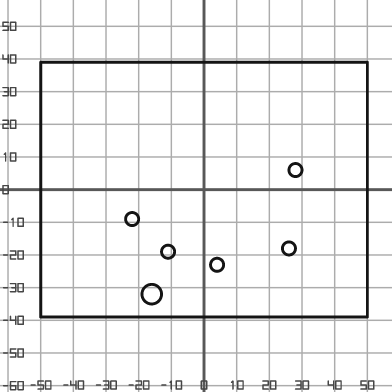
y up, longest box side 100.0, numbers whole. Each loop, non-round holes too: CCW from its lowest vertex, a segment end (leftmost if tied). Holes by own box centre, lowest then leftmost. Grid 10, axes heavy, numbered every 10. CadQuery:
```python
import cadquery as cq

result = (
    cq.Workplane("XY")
    .moveTo(-50.0, -39.0)
    .lineTo(50.0, -39.0)
    .lineTo(50.0, 39.0)
    .lineTo(-50.0, 39.0)
    .close()
    .moveTo(-16.0, -32.0)
    .circle(3.0)
    .moveTo(4.0, -23.0)
    .circle(2.0)
    .moveTo(-11.0, -19.0)
    .circle(2.0)
    .moveTo(26.0, -18.0)
    .circle(2.0)
    .moveTo(-22.0, -9.0)
    .circle(2.0)
    .moveTo(28.0, 6.0)
    .circle(2.0)
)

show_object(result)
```